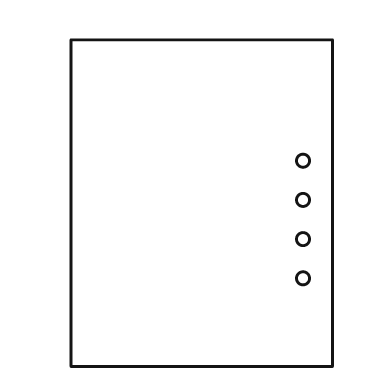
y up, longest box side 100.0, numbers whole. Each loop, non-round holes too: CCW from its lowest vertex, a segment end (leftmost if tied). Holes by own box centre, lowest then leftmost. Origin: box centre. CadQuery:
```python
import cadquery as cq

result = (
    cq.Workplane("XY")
    .moveTo(-40.0, -50.0)
    .lineTo(40.0, -50.0)
    .lineTo(40.0, 50.0)
    .lineTo(-40.0, 50.0)
    .close()
    .moveTo(31.0, -23.0)
    .circle(2.0)
    .moveTo(31.0, -11.0)
    .circle(2.0)
    .moveTo(31.0, 1.0)
    .circle(2.0)
    .moveTo(31.0, 13.0)
    .circle(2.0)
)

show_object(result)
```